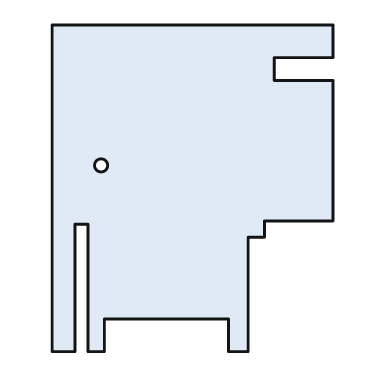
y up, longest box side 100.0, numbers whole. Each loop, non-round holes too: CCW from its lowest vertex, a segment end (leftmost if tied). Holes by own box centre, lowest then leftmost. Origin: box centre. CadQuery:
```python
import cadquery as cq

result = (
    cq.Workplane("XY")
    .moveTo(-43.0, -50.0)
    .lineTo(-36.0, -50.0)
    .lineTo(-36.0, -11.0)
    .lineTo(-32.0, -11.0)
    .lineTo(-32.0, -50.0)
    .lineTo(-27.0, -50.0)
    .lineTo(-27.0, -40.0)
    .lineTo(11.0, -40.0)
    .lineTo(11.0, -50.0)
    .lineTo(17.0, -50.0)
    .lineTo(17.0, -15.0)
    .lineTo(22.0, -15.0)
    .lineTo(22.0, -10.0)
    .lineTo(43.0, -10.0)
    .lineTo(43.0, 33.0)
    .lineTo(25.0, 33.0)
    .lineTo(25.0, 40.0)
    .lineTo(43.0, 40.0)
    .lineTo(43.0, 50.0)
    .lineTo(-43.0, 50.0)
    .close()
    .moveTo(-28.0, 7.0)
    .circle(2.0)
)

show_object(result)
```